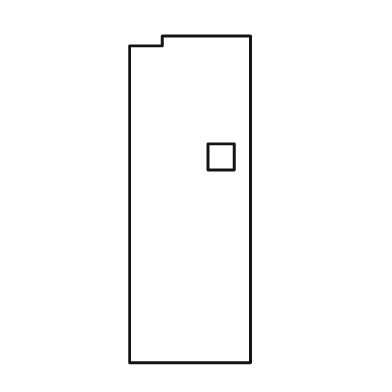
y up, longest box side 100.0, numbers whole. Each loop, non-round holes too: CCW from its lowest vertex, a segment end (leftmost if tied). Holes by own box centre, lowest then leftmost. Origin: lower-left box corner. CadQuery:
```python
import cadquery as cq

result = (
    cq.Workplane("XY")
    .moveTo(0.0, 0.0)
    .lineTo(37.0, 0.0)
    .lineTo(37.0, 100.0)
    .lineTo(10.0, 100.0)
    .lineTo(10.0, 97.0)
    .lineTo(0.0, 97.0)
    .close()
    .moveTo(24.0, 59.0)
    .lineTo(32.0, 59.0)
    .lineTo(32.0, 67.0)
    .lineTo(24.0, 67.0)
    .close()
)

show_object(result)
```